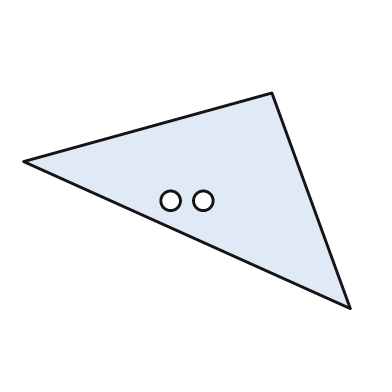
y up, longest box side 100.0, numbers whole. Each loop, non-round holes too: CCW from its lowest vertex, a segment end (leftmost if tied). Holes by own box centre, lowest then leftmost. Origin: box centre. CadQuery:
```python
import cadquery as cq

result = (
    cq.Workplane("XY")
    .moveTo(50.0, -33.0)
    .lineTo(26.0, 33.0)
    .lineTo(-50.0, 12.0)
    .close()
    .moveTo(-5.0, 0.0)
    .circle(3.0)
    .moveTo(5.0, 0.0)
    .circle(3.0)
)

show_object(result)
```